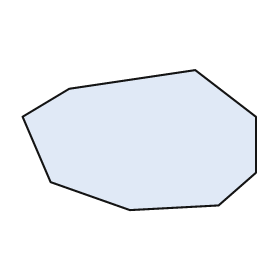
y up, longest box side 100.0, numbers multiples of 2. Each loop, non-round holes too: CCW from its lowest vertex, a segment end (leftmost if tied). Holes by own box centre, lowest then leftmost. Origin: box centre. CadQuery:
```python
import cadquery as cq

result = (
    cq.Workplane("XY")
    .moveTo(-4.0, -30.0)
    .lineTo(34.0, -28.0)
    .lineTo(50.0, -14.0)
    .lineTo(50.0, 10.0)
    .lineTo(24.0, 30.0)
    .lineTo(-30.0, 22.0)
    .lineTo(-50.0, 10.0)
    .lineTo(-38.0, -18.0)
    .close()
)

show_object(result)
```